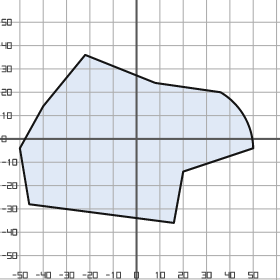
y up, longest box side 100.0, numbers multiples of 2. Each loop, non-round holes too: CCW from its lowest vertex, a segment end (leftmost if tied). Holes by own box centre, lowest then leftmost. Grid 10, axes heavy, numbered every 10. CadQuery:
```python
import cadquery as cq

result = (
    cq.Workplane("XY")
    .moveTo(16.0, -36.0)
    .lineTo(20.0, -14.0)
    .lineTo(50.0, -4.0)
    .threePointArc((46.0, 10.0), (36.0, 20.0))
    .lineTo(8.0, 24.0)
    .lineTo(-22.0, 36.0)
    .lineTo(-40.0, 14.0)
    .lineTo(-50.0, -4.0)
    .lineTo(-46.0, -28.0)
    .close()
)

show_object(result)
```